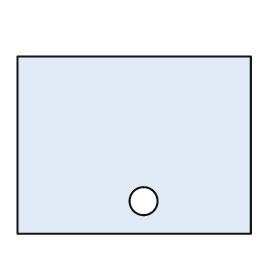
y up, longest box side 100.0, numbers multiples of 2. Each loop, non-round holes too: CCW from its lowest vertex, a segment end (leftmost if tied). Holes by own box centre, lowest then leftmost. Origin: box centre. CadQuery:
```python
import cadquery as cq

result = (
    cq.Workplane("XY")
    .moveTo(-50.0, -38.0)
    .lineTo(50.0, -38.0)
    .lineTo(50.0, 38.0)
    .lineTo(-50.0, 38.0)
    .close()
    .moveTo(4.0, -24.0)
    .circle(6.0)
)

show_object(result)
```